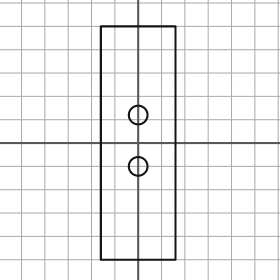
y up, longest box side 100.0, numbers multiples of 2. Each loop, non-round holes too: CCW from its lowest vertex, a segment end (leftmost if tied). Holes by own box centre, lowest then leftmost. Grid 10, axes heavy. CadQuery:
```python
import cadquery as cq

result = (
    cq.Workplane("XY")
    .moveTo(-16.0, -50.0)
    .lineTo(16.0, -50.0)
    .lineTo(16.0, 50.0)
    .lineTo(-16.0, 50.0)
    .close()
    .moveTo(0.0, -10.0)
    .circle(4.0)
    .moveTo(0.0, 12.0)
    .circle(4.0)
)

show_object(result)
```